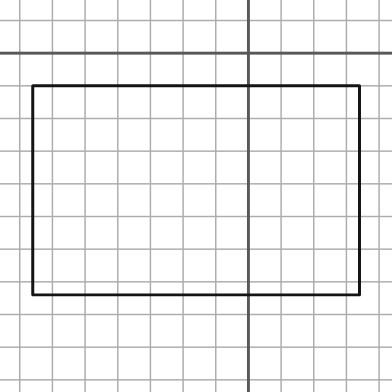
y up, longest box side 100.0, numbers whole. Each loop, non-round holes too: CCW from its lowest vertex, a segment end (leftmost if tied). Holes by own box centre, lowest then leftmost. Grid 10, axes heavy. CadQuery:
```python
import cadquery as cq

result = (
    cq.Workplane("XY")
    .moveTo(-66.0, -74.0)
    .lineTo(34.0, -74.0)
    .lineTo(34.0, -10.0)
    .lineTo(-66.0, -10.0)
    .close()
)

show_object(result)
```